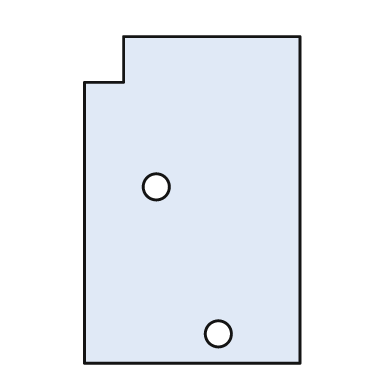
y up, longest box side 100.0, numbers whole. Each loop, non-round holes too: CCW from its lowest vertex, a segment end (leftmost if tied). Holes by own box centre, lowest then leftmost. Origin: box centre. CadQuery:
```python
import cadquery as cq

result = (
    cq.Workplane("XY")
    .moveTo(-33.0, -50.0)
    .lineTo(33.0, -50.0)
    .lineTo(33.0, 50.0)
    .lineTo(-21.0, 50.0)
    .lineTo(-21.0, 36.0)
    .lineTo(-33.0, 36.0)
    .close()
    .moveTo(8.0, -41.0)
    .circle(4.0)
    .moveTo(-11.0, 4.0)
    .circle(4.0)
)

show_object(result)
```